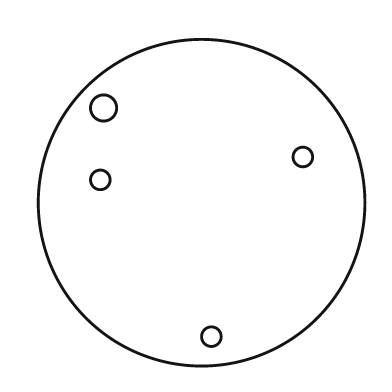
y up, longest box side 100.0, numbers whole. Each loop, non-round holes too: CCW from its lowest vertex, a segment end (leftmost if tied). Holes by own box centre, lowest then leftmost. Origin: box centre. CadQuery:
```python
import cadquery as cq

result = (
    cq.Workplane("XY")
    .moveTo(0.0, 0.0)
    .circle(50.0)
    .moveTo(3.0, -41.0)
    .circle(3.0)
    .moveTo(-31.0, 7.0)
    .circle(3.0)
    .moveTo(31.0, 14.0)
    .circle(3.0)
    .moveTo(-30.0, 29.0)
    .circle(4.0)
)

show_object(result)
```